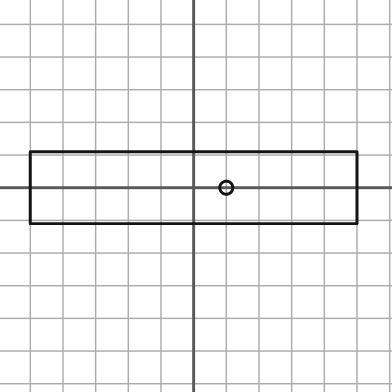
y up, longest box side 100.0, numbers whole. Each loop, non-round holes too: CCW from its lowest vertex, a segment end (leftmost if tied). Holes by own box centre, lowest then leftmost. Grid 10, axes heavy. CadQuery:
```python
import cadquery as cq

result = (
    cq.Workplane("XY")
    .moveTo(-50.0, -11.0)
    .lineTo(50.0, -11.0)
    .lineTo(50.0, 11.0)
    .lineTo(-50.0, 11.0)
    .close()
    .moveTo(10.0, 0.0)
    .circle(2.0)
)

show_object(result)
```